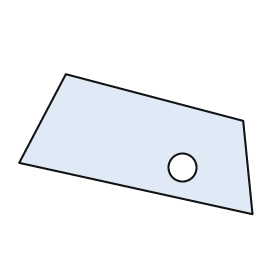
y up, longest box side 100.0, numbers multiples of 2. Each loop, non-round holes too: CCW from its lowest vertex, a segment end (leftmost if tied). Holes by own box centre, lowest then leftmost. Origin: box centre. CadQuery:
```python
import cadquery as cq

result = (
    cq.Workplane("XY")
    .moveTo(50.0, -30.0)
    .lineTo(46.0, 10.0)
    .lineTo(-30.0, 30.0)
    .lineTo(-50.0, -8.0)
    .close()
    .moveTo(20.0, -10.0)
    .circle(6.0)
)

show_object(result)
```